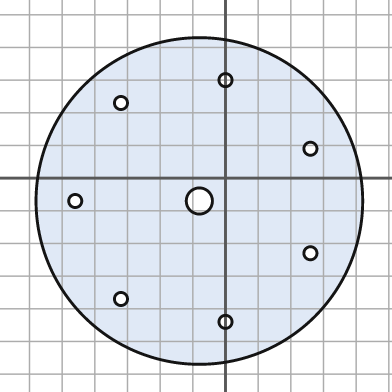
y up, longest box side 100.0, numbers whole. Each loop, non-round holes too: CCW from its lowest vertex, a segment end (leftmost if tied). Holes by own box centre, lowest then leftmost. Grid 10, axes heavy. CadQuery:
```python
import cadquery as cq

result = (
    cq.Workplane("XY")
    .moveTo(-8.0, -7.0)
    .circle(50.0)
    .moveTo(0.0, -44.0)
    .circle(2.0)
    .moveTo(-32.0, -37.0)
    .circle(2.0)
    .moveTo(26.0, -23.0)
    .circle(2.0)
    .moveTo(-46.0, -7.0)
    .circle(2.0)
    .moveTo(-8.0, -7.0)
    .circle(4.0)
    .moveTo(26.0, 9.0)
    .circle(2.0)
    .moveTo(-32.0, 23.0)
    .circle(2.0)
    .moveTo(0.0, 30.0)
    .circle(2.0)
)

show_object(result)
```